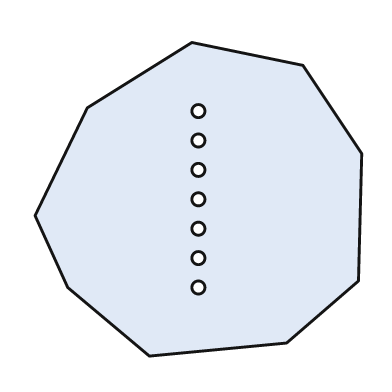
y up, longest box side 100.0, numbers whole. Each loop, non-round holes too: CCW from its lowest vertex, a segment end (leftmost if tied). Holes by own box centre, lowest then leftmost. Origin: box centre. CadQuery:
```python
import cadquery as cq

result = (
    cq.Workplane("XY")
    .moveTo(-15.0, -48.0)
    .lineTo(27.0, -44.0)
    .lineTo(49.0, -25.0)
    .lineTo(50.0, 14.0)
    .lineTo(32.0, 41.0)
    .lineTo(-2.0, 48.0)
    .lineTo(-34.0, 28.0)
    .lineTo(-50.0, -5.0)
    .lineTo(-40.0, -27.0)
    .close()
    .moveTo(0.0, -27.0)
    .circle(2.0)
    .moveTo(0.0, -18.0)
    .circle(2.0)
    .moveTo(0.0, -9.0)
    .circle(2.0)
    .moveTo(0.0, 0.0)
    .circle(2.0)
    .moveTo(0.0, 9.0)
    .circle(2.0)
    .moveTo(0.0, 18.0)
    .circle(2.0)
    .moveTo(0.0, 27.0)
    .circle(2.0)
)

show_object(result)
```